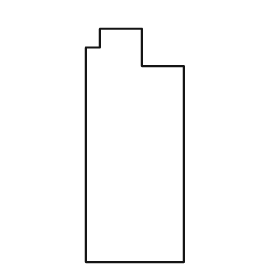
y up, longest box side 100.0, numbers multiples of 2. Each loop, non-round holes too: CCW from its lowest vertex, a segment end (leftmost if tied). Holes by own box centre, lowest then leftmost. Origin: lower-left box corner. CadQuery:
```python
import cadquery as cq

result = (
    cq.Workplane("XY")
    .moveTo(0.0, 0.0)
    .lineTo(42.0, 0.0)
    .lineTo(42.0, 84.0)
    .lineTo(24.0, 84.0)
    .lineTo(24.0, 100.0)
    .lineTo(6.0, 100.0)
    .lineTo(6.0, 92.0)
    .lineTo(0.0, 92.0)
    .close()
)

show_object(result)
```